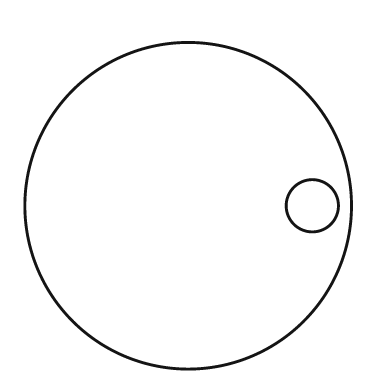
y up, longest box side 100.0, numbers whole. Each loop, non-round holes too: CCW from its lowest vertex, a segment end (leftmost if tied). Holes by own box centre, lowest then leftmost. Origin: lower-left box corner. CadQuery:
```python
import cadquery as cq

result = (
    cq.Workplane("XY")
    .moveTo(50.0, 50.0)
    .circle(50.0)
    .moveTo(88.0, 50.0)
    .circle(8.0)
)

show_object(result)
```